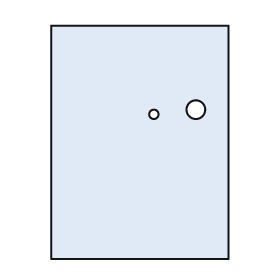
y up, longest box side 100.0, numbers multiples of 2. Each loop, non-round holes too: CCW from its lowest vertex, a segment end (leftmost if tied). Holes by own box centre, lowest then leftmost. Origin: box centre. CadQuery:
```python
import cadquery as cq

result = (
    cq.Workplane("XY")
    .moveTo(-38.0, -50.0)
    .lineTo(38.0, -50.0)
    .lineTo(38.0, 50.0)
    .lineTo(-38.0, 50.0)
    .close()
    .moveTo(6.0, 12.0)
    .circle(2.0)
    .moveTo(24.0, 14.0)
    .circle(4.0)
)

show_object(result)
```